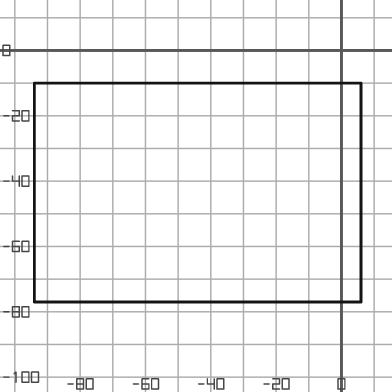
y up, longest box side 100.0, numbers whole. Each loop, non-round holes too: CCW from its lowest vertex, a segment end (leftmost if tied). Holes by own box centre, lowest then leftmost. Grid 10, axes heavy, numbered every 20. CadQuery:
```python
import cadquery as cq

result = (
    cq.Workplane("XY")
    .moveTo(-94.0, -77.0)
    .lineTo(6.0, -77.0)
    .lineTo(6.0, -10.0)
    .lineTo(-94.0, -10.0)
    .close()
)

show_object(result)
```